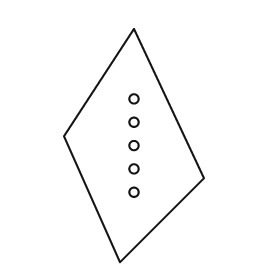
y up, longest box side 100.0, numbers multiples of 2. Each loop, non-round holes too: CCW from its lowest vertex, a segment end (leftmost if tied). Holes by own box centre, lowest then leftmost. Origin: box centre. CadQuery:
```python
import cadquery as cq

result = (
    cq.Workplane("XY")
    .moveTo(-6.0, -50.0)
    .lineTo(30.0, -14.0)
    .lineTo(0.0, 50.0)
    .lineTo(-30.0, 4.0)
    .close()
    .moveTo(0.0, -20.0)
    .circle(2.0)
    .moveTo(0.0, -10.0)
    .circle(2.0)
    .moveTo(0.0, 0.0)
    .circle(2.0)
    .moveTo(0.0, 10.0)
    .circle(2.0)
    .moveTo(0.0, 20.0)
    .circle(2.0)
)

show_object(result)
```